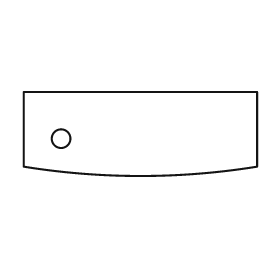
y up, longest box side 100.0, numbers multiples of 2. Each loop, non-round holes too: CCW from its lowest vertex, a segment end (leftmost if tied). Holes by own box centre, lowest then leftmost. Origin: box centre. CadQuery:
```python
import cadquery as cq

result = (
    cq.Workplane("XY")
    .moveTo(-50.0, -14.0)
    .threePointArc((0.0, -18.0), (50.0, -14.0))
    .lineTo(50.0, 18.0)
    .lineTo(-50.0, 18.0)
    .close()
    .moveTo(-34.0, -2.0)
    .circle(4.0)
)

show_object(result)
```